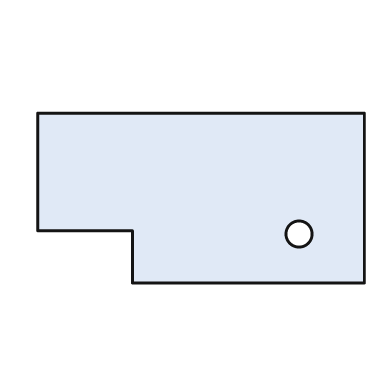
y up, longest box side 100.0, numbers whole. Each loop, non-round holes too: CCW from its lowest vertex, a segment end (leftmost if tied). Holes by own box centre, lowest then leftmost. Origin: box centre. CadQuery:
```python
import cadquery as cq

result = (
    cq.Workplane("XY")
    .moveTo(-21.0, -26.0)
    .lineTo(50.0, -26.0)
    .lineTo(50.0, 26.0)
    .lineTo(-50.0, 26.0)
    .lineTo(-50.0, -10.0)
    .lineTo(-21.0, -10.0)
    .close()
    .moveTo(30.0, -11.0)
    .circle(4.0)
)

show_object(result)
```